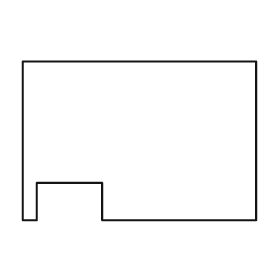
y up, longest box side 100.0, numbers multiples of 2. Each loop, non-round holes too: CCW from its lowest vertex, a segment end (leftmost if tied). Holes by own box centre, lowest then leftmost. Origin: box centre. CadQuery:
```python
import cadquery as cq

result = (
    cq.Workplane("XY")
    .moveTo(-50.0, -34.0)
    .lineTo(-44.0, -34.0)
    .lineTo(-44.0, -18.0)
    .lineTo(-16.0, -18.0)
    .lineTo(-16.0, -34.0)
    .lineTo(50.0, -34.0)
    .lineTo(50.0, 34.0)
    .lineTo(-50.0, 34.0)
    .close()
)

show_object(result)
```